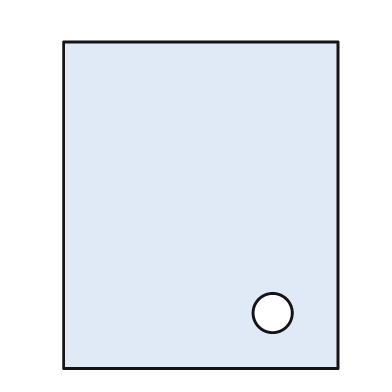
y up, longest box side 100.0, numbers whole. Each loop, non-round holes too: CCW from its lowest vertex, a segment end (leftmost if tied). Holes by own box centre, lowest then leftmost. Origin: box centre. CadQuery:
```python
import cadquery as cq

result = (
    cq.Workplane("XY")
    .moveTo(-42.0, -50.0)
    .lineTo(42.0, -50.0)
    .lineTo(42.0, 50.0)
    .lineTo(-42.0, 50.0)
    .close()
    .moveTo(22.0, -33.0)
    .circle(6.0)
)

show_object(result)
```